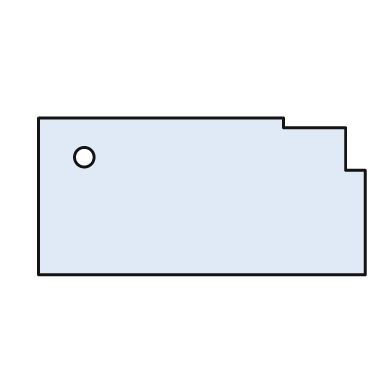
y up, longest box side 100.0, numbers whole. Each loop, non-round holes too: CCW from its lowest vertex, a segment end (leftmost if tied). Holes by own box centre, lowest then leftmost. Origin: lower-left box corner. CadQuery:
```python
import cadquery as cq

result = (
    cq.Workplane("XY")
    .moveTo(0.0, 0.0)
    .lineTo(100.0, 0.0)
    .lineTo(100.0, 32.0)
    .lineTo(94.0, 32.0)
    .lineTo(94.0, 45.0)
    .lineTo(75.0, 45.0)
    .lineTo(75.0, 48.0)
    .lineTo(0.0, 48.0)
    .close()
    .moveTo(14.0, 36.0)
    .circle(3.0)
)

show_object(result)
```